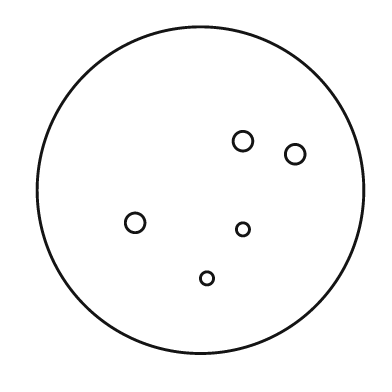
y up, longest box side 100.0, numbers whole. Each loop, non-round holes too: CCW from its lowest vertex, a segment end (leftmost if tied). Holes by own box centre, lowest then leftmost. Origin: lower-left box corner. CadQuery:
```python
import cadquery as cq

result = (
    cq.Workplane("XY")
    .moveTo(50.0, 50.0)
    .circle(50.0)
    .moveTo(52.0, 23.0)
    .circle(2.0)
    .moveTo(63.0, 38.0)
    .circle(2.0)
    .moveTo(30.0, 40.0)
    .circle(3.0)
    .moveTo(79.0, 61.0)
    .circle(3.0)
    .moveTo(63.0, 65.0)
    .circle(3.0)
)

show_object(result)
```